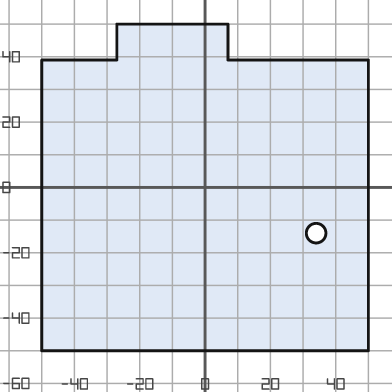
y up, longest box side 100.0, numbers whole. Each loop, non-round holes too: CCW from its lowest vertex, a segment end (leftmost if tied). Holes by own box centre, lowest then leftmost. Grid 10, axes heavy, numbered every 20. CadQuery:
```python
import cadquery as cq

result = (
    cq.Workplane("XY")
    .moveTo(-50.0, -50.0)
    .lineTo(50.0, -50.0)
    .lineTo(50.0, 39.0)
    .lineTo(7.0, 39.0)
    .lineTo(7.0, 50.0)
    .lineTo(-27.0, 50.0)
    .lineTo(-27.0, 39.0)
    .lineTo(-50.0, 39.0)
    .close()
    .moveTo(34.0, -14.0)
    .circle(3.0)
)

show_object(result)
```